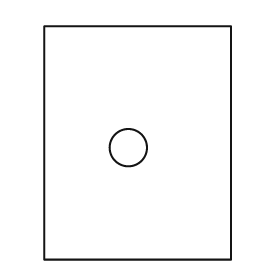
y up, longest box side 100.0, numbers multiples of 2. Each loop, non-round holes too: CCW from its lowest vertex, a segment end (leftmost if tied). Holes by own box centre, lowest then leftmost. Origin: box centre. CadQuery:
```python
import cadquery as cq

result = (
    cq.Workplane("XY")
    .moveTo(-40.0, -50.0)
    .lineTo(40.0, -50.0)
    .lineTo(40.0, 50.0)
    .lineTo(-40.0, 50.0)
    .close()
    .moveTo(-4.0, -2.0)
    .circle(8.0)
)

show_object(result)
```